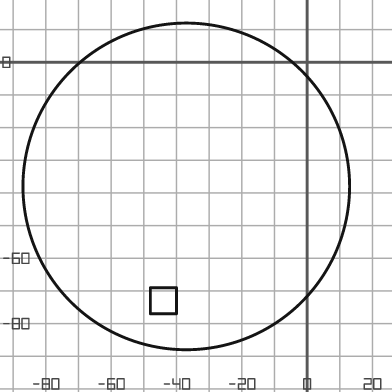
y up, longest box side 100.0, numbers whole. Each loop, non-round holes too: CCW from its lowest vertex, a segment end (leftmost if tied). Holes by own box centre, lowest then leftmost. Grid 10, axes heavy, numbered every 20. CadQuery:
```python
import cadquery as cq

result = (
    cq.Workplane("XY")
    .moveTo(-37.0, -38.0)
    .circle(50.0)
    .moveTo(-48.0, -77.0)
    .lineTo(-40.0, -77.0)
    .lineTo(-40.0, -69.0)
    .lineTo(-48.0, -69.0)
    .close()
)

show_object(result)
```